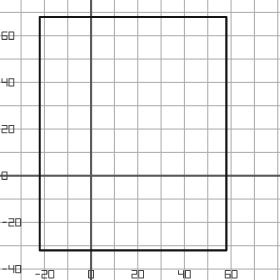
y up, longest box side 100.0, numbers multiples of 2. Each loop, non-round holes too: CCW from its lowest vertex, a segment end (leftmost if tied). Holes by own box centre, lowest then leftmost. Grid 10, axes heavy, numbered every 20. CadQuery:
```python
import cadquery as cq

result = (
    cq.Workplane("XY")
    .moveTo(-22.0, -32.0)
    .lineTo(58.0, -32.0)
    .lineTo(58.0, 68.0)
    .lineTo(-22.0, 68.0)
    .close()
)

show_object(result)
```